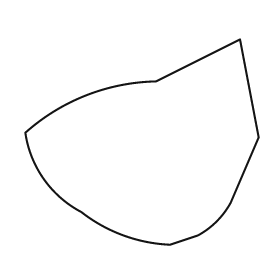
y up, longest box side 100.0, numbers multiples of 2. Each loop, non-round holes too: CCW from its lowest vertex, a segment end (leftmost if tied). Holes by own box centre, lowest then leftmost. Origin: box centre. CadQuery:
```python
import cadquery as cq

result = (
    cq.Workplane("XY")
    .moveTo(12.0, -44.0)
    .lineTo(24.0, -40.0)
    .threePointArc((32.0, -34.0), (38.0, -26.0))
    .lineTo(50.0, 2.0)
    .lineTo(42.0, 44.0)
    .lineTo(6.0, 26.0)
    .threePointArc((-24.0, 20.0), (-50.0, 4.0))
    .threePointArc((-42.0, -16.0), (-26.0, -30.0))
    .threePointArc((-8.0, -40.0), (12.0, -44.0))
    .close()
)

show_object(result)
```